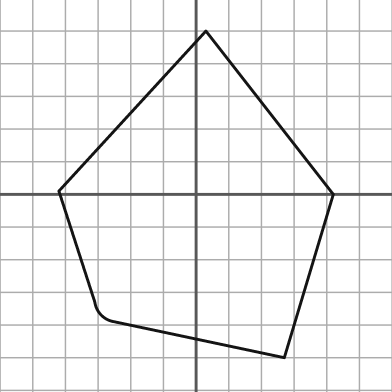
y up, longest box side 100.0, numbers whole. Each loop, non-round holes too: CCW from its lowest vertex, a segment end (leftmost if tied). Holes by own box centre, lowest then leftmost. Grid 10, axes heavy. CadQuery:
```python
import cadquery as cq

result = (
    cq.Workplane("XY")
    .moveTo(27.0, -50.0)
    .lineTo(42.0, 0.0)
    .lineTo(3.0, 50.0)
    .lineTo(-42.0, 1.0)
    .lineTo(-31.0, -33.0)
    .threePointArc((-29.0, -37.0), (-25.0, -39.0))
    .close()
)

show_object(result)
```